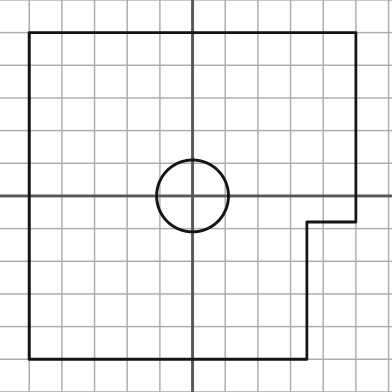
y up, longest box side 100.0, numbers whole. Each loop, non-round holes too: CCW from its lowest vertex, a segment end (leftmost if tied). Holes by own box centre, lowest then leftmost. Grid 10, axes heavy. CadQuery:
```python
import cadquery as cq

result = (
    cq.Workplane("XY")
    .moveTo(-50.0, -50.0)
    .lineTo(35.0, -50.0)
    .lineTo(35.0, -8.0)
    .lineTo(50.0, -8.0)
    .lineTo(50.0, 50.0)
    .lineTo(-50.0, 50.0)
    .close()
    .moveTo(0.0, 0.0)
    .circle(11.0)
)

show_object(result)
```